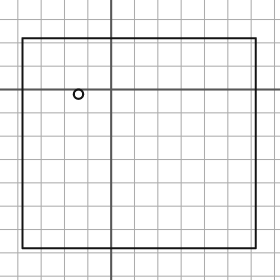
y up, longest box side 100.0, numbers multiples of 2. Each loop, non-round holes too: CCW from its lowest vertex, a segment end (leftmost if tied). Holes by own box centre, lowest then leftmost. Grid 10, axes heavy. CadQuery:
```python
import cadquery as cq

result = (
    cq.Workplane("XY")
    .moveTo(-38.0, -68.0)
    .lineTo(62.0, -68.0)
    .lineTo(62.0, 22.0)
    .lineTo(-38.0, 22.0)
    .close()
    .moveTo(-14.0, -2.0)
    .circle(2.0)
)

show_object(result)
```